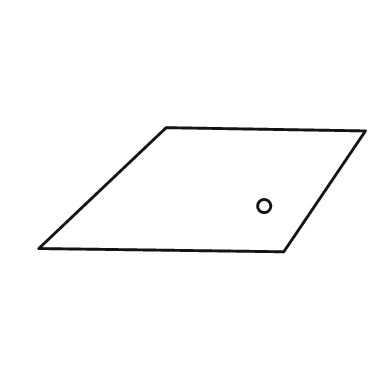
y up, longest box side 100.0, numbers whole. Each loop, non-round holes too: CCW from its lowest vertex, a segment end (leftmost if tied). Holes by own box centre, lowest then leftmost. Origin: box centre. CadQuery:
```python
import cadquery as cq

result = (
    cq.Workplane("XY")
    .moveTo(25.0, -19.0)
    .lineTo(50.0, 18.0)
    .lineTo(-11.0, 19.0)
    .lineTo(-50.0, -18.0)
    .close()
    .moveTo(19.0, -5.0)
    .circle(2.0)
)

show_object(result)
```